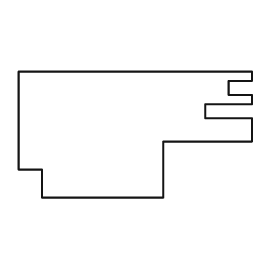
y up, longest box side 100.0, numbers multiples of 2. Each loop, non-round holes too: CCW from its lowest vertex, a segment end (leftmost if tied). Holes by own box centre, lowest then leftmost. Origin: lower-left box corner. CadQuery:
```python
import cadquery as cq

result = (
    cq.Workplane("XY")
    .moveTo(10.0, 0.0)
    .lineTo(62.0, 0.0)
    .lineTo(62.0, 24.0)
    .lineTo(100.0, 24.0)
    .lineTo(100.0, 34.0)
    .lineTo(80.0, 34.0)
    .lineTo(80.0, 40.0)
    .lineTo(100.0, 40.0)
    .lineTo(100.0, 44.0)
    .lineTo(90.0, 44.0)
    .lineTo(90.0, 50.0)
    .lineTo(100.0, 50.0)
    .lineTo(100.0, 54.0)
    .lineTo(0.0, 54.0)
    .lineTo(0.0, 12.0)
    .lineTo(10.0, 12.0)
    .close()
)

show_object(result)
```